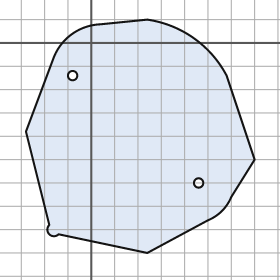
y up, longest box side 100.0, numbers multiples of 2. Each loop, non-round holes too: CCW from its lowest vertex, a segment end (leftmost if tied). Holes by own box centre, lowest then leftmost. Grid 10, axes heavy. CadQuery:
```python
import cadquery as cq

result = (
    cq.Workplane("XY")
    .moveTo(24.0, -90.0)
    .lineTo(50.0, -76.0)
    .threePointArc((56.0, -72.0), (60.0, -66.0))
    .lineTo(70.0, -50.0)
    .lineTo(58.0, -14.0)
    .threePointArc((44.0, 2.0), (24.0, 10.0))
    .lineTo(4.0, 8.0)
    .threePointArc((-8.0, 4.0), (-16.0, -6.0))
    .lineTo(-28.0, -38.0)
    .lineTo(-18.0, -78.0)
    .threePointArc((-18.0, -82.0), (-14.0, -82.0))
    .close()
    .moveTo(46.0, -60.0)
    .circle(2.0)
    .moveTo(-8.0, -14.0)
    .circle(2.0)
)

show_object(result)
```